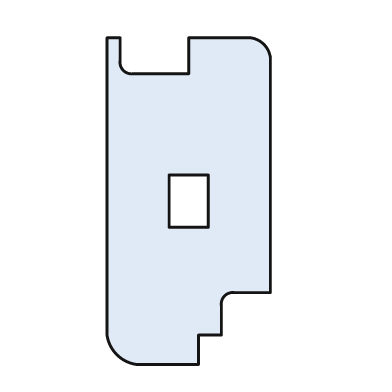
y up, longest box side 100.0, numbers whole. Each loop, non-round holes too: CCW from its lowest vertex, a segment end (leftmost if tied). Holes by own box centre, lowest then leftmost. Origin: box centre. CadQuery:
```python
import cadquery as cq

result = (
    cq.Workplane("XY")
    .moveTo(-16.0, -50.0)
    .lineTo(3.0, -50.0)
    .lineTo(3.0, -41.0)
    .lineTo(10.0, -41.0)
    .lineTo(10.0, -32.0)
    .threePointArc((11.0, -29.0), (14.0, -28.0))
    .lineTo(25.0, -28.0)
    .lineTo(25.0, 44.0)
    .threePointArc((23.0, 48.0), (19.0, 50.0))
    .lineTo(0.0, 50.0)
    .lineTo(0.0, 39.0)
    .lineTo(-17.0, 39.0)
    .threePointArc((-20.0, 40.0), (-21.0, 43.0))
    .lineTo(-21.0, 50.0)
    .lineTo(-25.0, 50.0)
    .lineTo(-25.0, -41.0)
    .threePointArc((-22.0, -47.0), (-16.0, -50.0))
    .close()
    .moveTo(-6.0, -8.0)
    .lineTo(6.0, -8.0)
    .lineTo(6.0, 8.0)
    .lineTo(-6.0, 8.0)
    .close()
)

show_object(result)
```